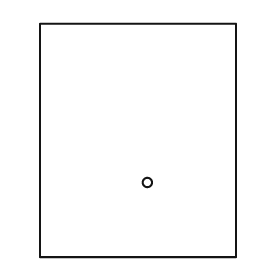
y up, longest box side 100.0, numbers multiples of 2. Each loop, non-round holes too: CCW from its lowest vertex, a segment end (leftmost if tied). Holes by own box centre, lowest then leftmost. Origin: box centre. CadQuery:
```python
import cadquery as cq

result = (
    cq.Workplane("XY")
    .moveTo(-42.0, -50.0)
    .lineTo(42.0, -50.0)
    .lineTo(42.0, 50.0)
    .lineTo(-42.0, 50.0)
    .close()
    .moveTo(4.0, -18.0)
    .circle(2.0)
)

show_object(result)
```